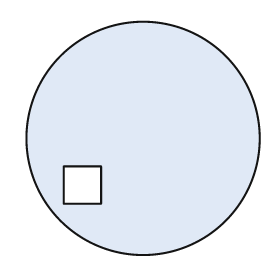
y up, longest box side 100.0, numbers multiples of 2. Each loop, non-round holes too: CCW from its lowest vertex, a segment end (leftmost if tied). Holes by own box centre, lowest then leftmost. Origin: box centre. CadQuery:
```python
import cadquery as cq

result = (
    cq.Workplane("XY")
    .moveTo(0.0, 0.0)
    .circle(50.0)
    .moveTo(-34.0, -28.0)
    .lineTo(-18.0, -28.0)
    .lineTo(-18.0, -12.0)
    .lineTo(-34.0, -12.0)
    .close()
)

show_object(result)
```